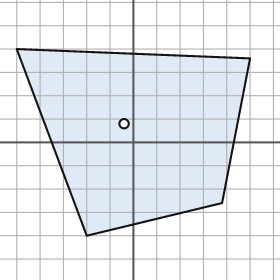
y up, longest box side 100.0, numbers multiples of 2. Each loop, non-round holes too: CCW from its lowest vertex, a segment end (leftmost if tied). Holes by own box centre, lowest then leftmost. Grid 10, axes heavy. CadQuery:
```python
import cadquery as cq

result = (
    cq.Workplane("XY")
    .moveTo(-20.0, -40.0)
    .lineTo(38.0, -26.0)
    .lineTo(50.0, 36.0)
    .lineTo(-50.0, 40.0)
    .close()
    .moveTo(-4.0, 8.0)
    .circle(2.0)
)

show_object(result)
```